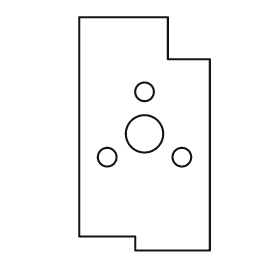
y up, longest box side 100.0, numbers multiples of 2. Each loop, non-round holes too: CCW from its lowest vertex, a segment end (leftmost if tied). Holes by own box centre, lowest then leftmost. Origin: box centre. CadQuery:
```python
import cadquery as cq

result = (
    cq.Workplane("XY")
    .moveTo(-4.0, -50.0)
    .lineTo(28.0, -50.0)
    .lineTo(28.0, 32.0)
    .lineTo(10.0, 32.0)
    .lineTo(10.0, 50.0)
    .lineTo(-28.0, 50.0)
    .lineTo(-28.0, -44.0)
    .lineTo(-4.0, -44.0)
    .close()
    .moveTo(-16.0, -10.0)
    .circle(4.0)
    .moveTo(16.0, -10.0)
    .circle(4.0)
    .moveTo(0.0, 0.0)
    .circle(8.0)
    .moveTo(0.0, 18.0)
    .circle(4.0)
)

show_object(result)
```